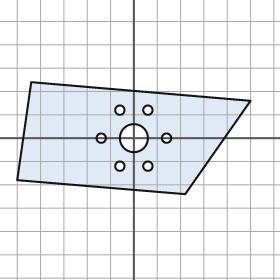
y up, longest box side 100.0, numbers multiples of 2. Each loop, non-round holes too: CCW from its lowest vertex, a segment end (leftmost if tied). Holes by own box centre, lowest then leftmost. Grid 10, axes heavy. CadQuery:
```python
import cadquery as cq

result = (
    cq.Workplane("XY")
    .moveTo(22.0, -24.0)
    .lineTo(50.0, 16.0)
    .lineTo(-44.0, 24.0)
    .lineTo(-50.0, -18.0)
    .close()
    .moveTo(-6.0, -12.0)
    .circle(2.0)
    .moveTo(6.0, -12.0)
    .circle(2.0)
    .moveTo(-14.0, 0.0)
    .circle(2.0)
    .moveTo(0.0, 0.0)
    .circle(6.0)
    .moveTo(14.0, 0.0)
    .circle(2.0)
    .moveTo(-6.0, 12.0)
    .circle(2.0)
    .moveTo(6.0, 12.0)
    .circle(2.0)
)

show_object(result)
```